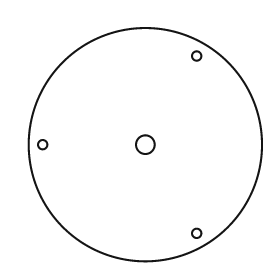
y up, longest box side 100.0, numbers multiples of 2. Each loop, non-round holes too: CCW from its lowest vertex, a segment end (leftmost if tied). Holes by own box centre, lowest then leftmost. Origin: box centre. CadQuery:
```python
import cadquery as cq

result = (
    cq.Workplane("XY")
    .moveTo(0.0, 0.0)
    .circle(50.0)
    .moveTo(22.0, -38.0)
    .circle(2.0)
    .moveTo(-44.0, 0.0)
    .circle(2.0)
    .moveTo(0.0, 0.0)
    .circle(4.0)
    .moveTo(22.0, 38.0)
    .circle(2.0)
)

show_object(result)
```